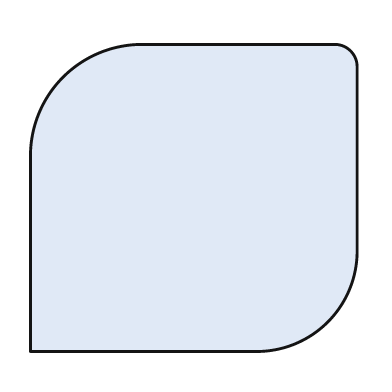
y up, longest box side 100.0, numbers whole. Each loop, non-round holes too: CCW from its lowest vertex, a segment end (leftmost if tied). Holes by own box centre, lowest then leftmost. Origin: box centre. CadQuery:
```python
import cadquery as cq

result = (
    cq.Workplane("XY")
    .moveTo(-50.0, -47.0)
    .lineTo(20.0, -47.0)
    .threePointArc((41.0, -38.0), (50.0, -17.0))
    .lineTo(50.0, 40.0)
    .threePointArc((48.0, 45.0), (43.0, 47.0))
    .lineTo(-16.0, 47.0)
    .threePointArc((-40.0, 37.0), (-50.0, 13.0))
    .close()
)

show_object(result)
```